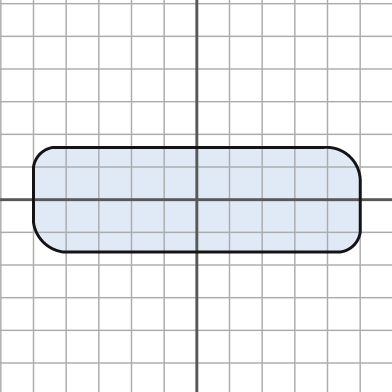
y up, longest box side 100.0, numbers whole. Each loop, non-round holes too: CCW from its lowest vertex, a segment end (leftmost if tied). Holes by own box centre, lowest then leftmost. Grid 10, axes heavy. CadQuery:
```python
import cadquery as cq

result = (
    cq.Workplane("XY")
    .moveTo(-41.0, -16.0)
    .lineTo(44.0, -16.0)
    .threePointArc((48.0, -14.0), (50.0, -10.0))
    .lineTo(50.0, 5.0)
    .threePointArc((47.0, 13.0), (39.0, 16.0))
    .lineTo(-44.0, 16.0)
    .threePointArc((-48.0, 14.0), (-50.0, 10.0))
    .lineTo(-50.0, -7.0)
    .threePointArc((-47.0, -13.0), (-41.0, -16.0))
    .close()
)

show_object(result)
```